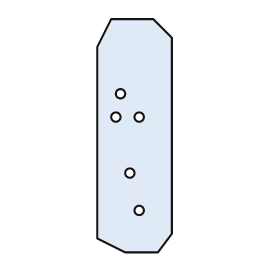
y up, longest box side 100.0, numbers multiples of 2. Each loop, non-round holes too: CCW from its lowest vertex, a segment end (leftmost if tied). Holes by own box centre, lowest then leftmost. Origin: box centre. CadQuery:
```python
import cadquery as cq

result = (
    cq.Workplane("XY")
    .moveTo(-4.0, -50.0)
    .lineTo(10.0, -50.0)
    .lineTo(16.0, -42.0)
    .lineTo(16.0, 42.0)
    .lineTo(8.0, 50.0)
    .lineTo(-10.0, 50.0)
    .lineTo(-16.0, 38.0)
    .lineTo(-16.0, -44.0)
    .close()
    .moveTo(2.0, -32.0)
    .circle(2.0)
    .moveTo(-2.0, -16.0)
    .circle(2.0)
    .moveTo(-8.0, 8.0)
    .circle(2.0)
    .moveTo(2.0, 8.0)
    .circle(2.0)
    .moveTo(-6.0, 18.0)
    .circle(2.0)
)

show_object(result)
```